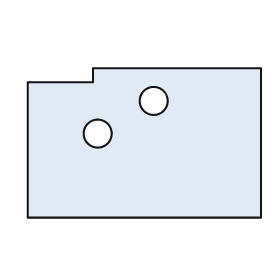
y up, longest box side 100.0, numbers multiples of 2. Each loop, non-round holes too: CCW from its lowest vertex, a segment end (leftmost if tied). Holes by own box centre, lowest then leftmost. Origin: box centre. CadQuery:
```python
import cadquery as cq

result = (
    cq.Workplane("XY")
    .moveTo(-50.0, -32.0)
    .lineTo(50.0, -32.0)
    .lineTo(50.0, 32.0)
    .lineTo(-22.0, 32.0)
    .lineTo(-22.0, 26.0)
    .lineTo(-50.0, 26.0)
    .close()
    .moveTo(-20.0, 4.0)
    .circle(6.0)
    .moveTo(4.0, 18.0)
    .circle(6.0)
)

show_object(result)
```